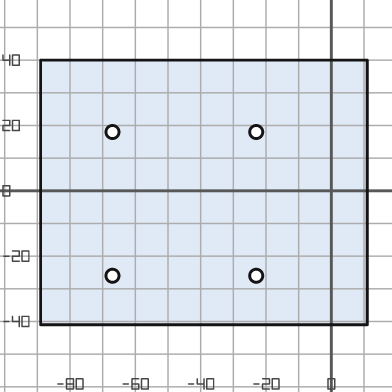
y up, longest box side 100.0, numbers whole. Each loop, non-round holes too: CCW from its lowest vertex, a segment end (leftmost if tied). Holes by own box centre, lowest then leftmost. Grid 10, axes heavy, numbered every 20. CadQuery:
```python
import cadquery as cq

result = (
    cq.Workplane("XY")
    .moveTo(-89.0, -41.0)
    .lineTo(11.0, -41.0)
    .lineTo(11.0, 40.0)
    .lineTo(-89.0, 40.0)
    .close()
    .moveTo(-67.0, -26.0)
    .circle(2.0)
    .moveTo(-23.0, -26.0)
    .circle(2.0)
    .moveTo(-67.0, 18.0)
    .circle(2.0)
    .moveTo(-23.0, 18.0)
    .circle(2.0)
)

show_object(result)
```